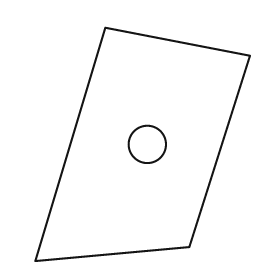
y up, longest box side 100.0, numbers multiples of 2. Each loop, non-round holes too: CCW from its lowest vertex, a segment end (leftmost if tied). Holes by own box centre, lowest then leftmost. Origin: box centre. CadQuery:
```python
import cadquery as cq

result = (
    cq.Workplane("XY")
    .moveTo(-46.0, -50.0)
    .lineTo(20.0, -44.0)
    .lineTo(46.0, 38.0)
    .lineTo(-16.0, 50.0)
    .close()
    .moveTo(2.0, 0.0)
    .circle(8.0)
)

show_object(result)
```